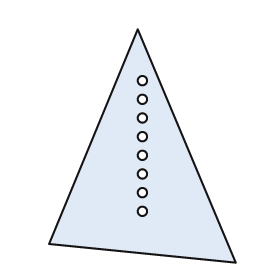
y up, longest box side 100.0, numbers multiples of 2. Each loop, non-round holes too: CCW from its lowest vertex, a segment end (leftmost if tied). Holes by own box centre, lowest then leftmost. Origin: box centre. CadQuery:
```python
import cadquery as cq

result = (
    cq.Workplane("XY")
    .moveTo(40.0, -50.0)
    .lineTo(-2.0, 50.0)
    .lineTo(-40.0, -42.0)
    .close()
    .moveTo(0.0, -28.0)
    .circle(2.0)
    .moveTo(0.0, -20.0)
    .circle(2.0)
    .moveTo(0.0, -12.0)
    .circle(2.0)
    .moveTo(0.0, -4.0)
    .circle(2.0)
    .moveTo(0.0, 4.0)
    .circle(2.0)
    .moveTo(0.0, 12.0)
    .circle(2.0)
    .moveTo(0.0, 20.0)
    .circle(2.0)
    .moveTo(0.0, 28.0)
    .circle(2.0)
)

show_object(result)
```